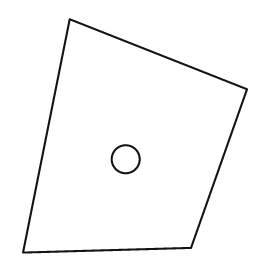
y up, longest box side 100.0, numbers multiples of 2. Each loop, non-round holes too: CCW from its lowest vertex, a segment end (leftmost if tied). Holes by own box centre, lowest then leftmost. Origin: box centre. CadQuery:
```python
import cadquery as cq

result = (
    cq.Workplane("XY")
    .moveTo(-48.0, -50.0)
    .lineTo(24.0, -48.0)
    .lineTo(48.0, 20.0)
    .lineTo(-28.0, 50.0)
    .close()
    .moveTo(-4.0, -10.0)
    .circle(6.0)
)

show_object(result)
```